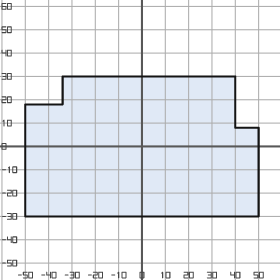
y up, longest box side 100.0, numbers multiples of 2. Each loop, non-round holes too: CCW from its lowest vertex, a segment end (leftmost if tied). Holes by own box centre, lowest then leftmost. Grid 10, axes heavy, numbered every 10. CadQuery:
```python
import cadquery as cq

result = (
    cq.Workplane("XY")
    .moveTo(-50.0, -30.0)
    .lineTo(50.0, -30.0)
    .lineTo(50.0, 8.0)
    .lineTo(40.0, 8.0)
    .lineTo(40.0, 30.0)
    .lineTo(-34.0, 30.0)
    .lineTo(-34.0, 18.0)
    .lineTo(-50.0, 18.0)
    .close()
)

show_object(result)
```